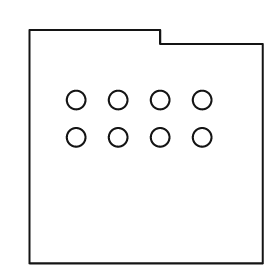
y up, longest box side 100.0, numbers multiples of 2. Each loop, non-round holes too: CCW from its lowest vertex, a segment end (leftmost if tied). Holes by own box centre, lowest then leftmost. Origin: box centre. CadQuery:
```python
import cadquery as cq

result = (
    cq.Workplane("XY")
    .moveTo(-50.0, -50.0)
    .lineTo(50.0, -50.0)
    .lineTo(50.0, 44.0)
    .lineTo(6.0, 44.0)
    .lineTo(6.0, 50.0)
    .lineTo(-50.0, 50.0)
    .close()
    .moveTo(-30.0, 4.0)
    .circle(4.0)
    .moveTo(-12.0, 4.0)
    .circle(4.0)
    .moveTo(6.0, 4.0)
    .circle(4.0)
    .moveTo(24.0, 4.0)
    .circle(4.0)
    .moveTo(-30.0, 20.0)
    .circle(4.0)
    .moveTo(-12.0, 20.0)
    .circle(4.0)
    .moveTo(6.0, 20.0)
    .circle(4.0)
    .moveTo(24.0, 20.0)
    .circle(4.0)
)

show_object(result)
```